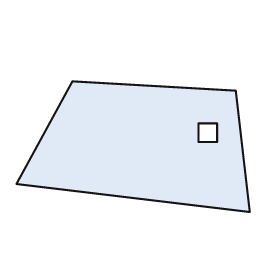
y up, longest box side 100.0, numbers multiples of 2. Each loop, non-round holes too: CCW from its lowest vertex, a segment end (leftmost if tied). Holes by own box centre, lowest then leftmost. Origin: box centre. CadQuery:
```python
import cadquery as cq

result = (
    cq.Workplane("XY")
    .moveTo(50.0, -28.0)
    .lineTo(44.0, 24.0)
    .lineTo(-26.0, 28.0)
    .lineTo(-50.0, -16.0)
    .close()
    .moveTo(28.0, 2.0)
    .lineTo(36.0, 2.0)
    .lineTo(36.0, 10.0)
    .lineTo(28.0, 10.0)
    .close()
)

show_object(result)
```